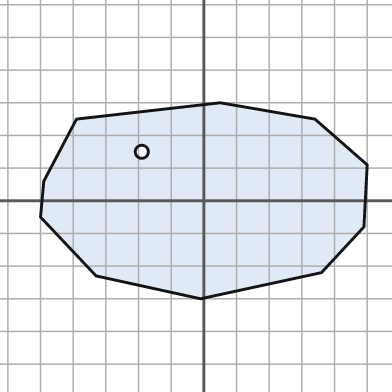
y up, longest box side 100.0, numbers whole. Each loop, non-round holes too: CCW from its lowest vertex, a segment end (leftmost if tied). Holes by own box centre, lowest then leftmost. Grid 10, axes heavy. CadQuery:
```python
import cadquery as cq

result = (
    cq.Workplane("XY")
    .moveTo(-1.0, -30.0)
    .lineTo(36.0, -22.0)
    .lineTo(49.0, -8.0)
    .lineTo(50.0, 11.0)
    .lineTo(34.0, 25.0)
    .lineTo(5.0, 30.0)
    .lineTo(-39.0, 25.0)
    .lineTo(-49.0, 6.0)
    .lineTo(-50.0, -5.0)
    .lineTo(-33.0, -23.0)
    .close()
    .moveTo(-19.0, 15.0)
    .circle(2.0)
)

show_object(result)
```